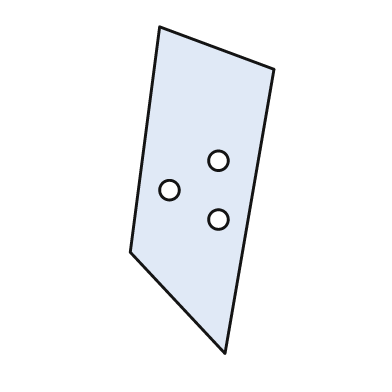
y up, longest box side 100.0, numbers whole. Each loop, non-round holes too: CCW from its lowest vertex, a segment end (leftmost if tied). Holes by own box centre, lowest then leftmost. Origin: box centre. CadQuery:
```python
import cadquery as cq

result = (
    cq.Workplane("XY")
    .moveTo(7.0, -50.0)
    .lineTo(22.0, 37.0)
    .lineTo(-13.0, 50.0)
    .lineTo(-22.0, -19.0)
    .close()
    .moveTo(5.0, -9.0)
    .circle(3.0)
    .moveTo(-10.0, 0.0)
    .circle(3.0)
    .moveTo(5.0, 9.0)
    .circle(3.0)
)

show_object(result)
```